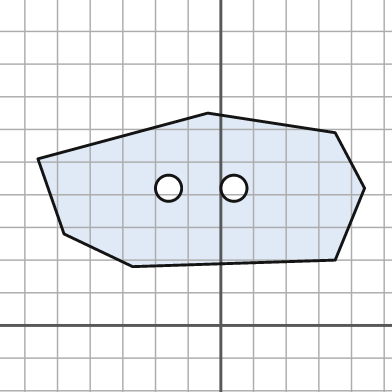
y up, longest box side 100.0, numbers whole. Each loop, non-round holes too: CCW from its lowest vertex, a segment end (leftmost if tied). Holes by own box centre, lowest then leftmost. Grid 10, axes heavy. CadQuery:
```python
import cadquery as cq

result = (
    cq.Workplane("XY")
    .moveTo(-27.0, 18.0)
    .lineTo(35.0, 20.0)
    .lineTo(44.0, 42.0)
    .lineTo(35.0, 59.0)
    .lineTo(-4.0, 65.0)
    .lineTo(-56.0, 51.0)
    .lineTo(-48.0, 28.0)
    .close()
    .moveTo(-16.0, 42.0)
    .circle(4.0)
    .moveTo(4.0, 42.0)
    .circle(4.0)
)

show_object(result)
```